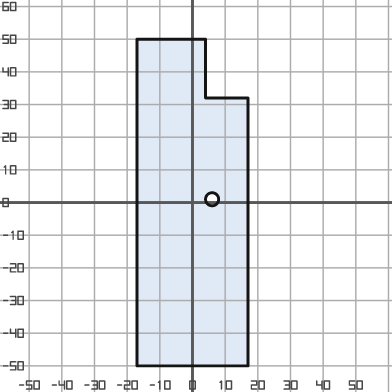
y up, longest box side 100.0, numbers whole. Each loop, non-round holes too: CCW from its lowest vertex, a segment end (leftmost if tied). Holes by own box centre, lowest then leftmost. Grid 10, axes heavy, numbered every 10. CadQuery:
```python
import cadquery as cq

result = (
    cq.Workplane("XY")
    .moveTo(-17.0, -50.0)
    .lineTo(17.0, -50.0)
    .lineTo(17.0, 32.0)
    .lineTo(4.0, 32.0)
    .lineTo(4.0, 50.0)
    .lineTo(-17.0, 50.0)
    .close()
    .moveTo(6.0, 1.0)
    .circle(2.0)
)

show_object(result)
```